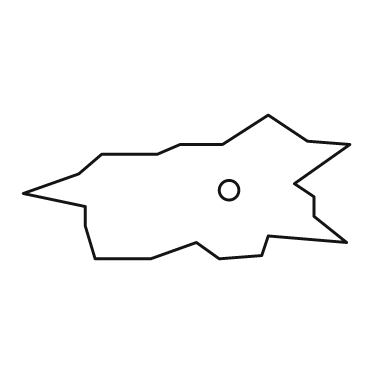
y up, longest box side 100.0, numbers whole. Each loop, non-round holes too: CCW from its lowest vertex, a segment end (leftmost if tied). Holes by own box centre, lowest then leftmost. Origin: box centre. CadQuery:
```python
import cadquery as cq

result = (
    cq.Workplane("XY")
    .moveTo(-28.0, -22.0)
    .lineTo(-11.0, -22.0)
    .lineTo(3.0, -17.0)
    .lineTo(10.0, -22.0)
    .lineTo(23.0, -21.0)
    .lineTo(25.0, -15.0)
    .lineTo(49.0, -17.0)
    .lineTo(39.0, -9.0)
    .lineTo(39.0, -3.0)
    .lineTo(33.0, 1.0)
    .lineTo(50.0, 13.0)
    .lineTo(37.0, 14.0)
    .lineTo(25.0, 22.0)
    .lineTo(11.0, 13.0)
    .lineTo(-2.0, 13.0)
    .lineTo(-9.0, 10.0)
    .lineTo(-26.0, 10.0)
    .lineTo(-33.0, 4.0)
    .lineTo(-50.0, -2.0)
    .lineTo(-31.0, -6.0)
    .lineTo(-31.0, -12.0)
    .close()
    .moveTo(13.0, -1.0)
    .circle(3.0)
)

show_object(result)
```